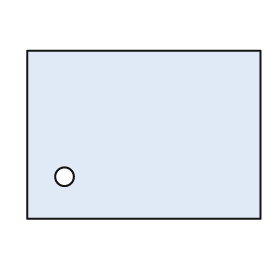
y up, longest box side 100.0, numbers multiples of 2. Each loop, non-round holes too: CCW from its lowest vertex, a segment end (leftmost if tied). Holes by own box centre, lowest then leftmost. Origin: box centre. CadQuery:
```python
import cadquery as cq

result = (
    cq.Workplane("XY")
    .moveTo(-50.0, -36.0)
    .lineTo(50.0, -36.0)
    .lineTo(50.0, 36.0)
    .lineTo(-50.0, 36.0)
    .close()
    .moveTo(-34.0, -18.0)
    .circle(4.0)
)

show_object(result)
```